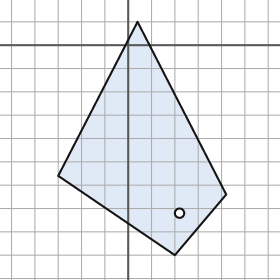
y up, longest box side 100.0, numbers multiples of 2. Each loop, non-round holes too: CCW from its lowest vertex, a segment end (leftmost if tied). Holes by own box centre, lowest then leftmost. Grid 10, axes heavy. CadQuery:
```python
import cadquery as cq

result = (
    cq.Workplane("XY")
    .moveTo(20.0, -90.0)
    .lineTo(42.0, -64.0)
    .lineTo(4.0, 10.0)
    .lineTo(-30.0, -56.0)
    .close()
    .moveTo(22.0, -72.0)
    .circle(2.0)
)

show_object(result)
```